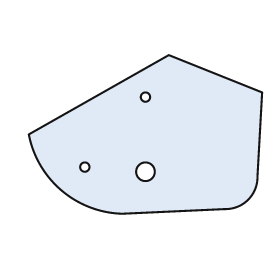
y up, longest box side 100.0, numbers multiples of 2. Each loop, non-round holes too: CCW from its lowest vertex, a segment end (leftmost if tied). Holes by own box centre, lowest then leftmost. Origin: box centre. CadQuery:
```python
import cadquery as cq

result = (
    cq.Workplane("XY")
    .moveTo(-10.0, -34.0)
    .lineTo(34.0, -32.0)
    .threePointArc((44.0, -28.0), (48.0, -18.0))
    .lineTo(50.0, 18.0)
    .lineTo(10.0, 34.0)
    .lineTo(-50.0, 0.0)
    .threePointArc((-36.0, -24.0), (-10.0, -34.0))
    .close()
    .moveTo(0.0, -16.0)
    .circle(4.0)
    .moveTo(-26.0, -14.0)
    .circle(2.0)
    .moveTo(0.0, 16.0)
    .circle(2.0)
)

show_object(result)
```